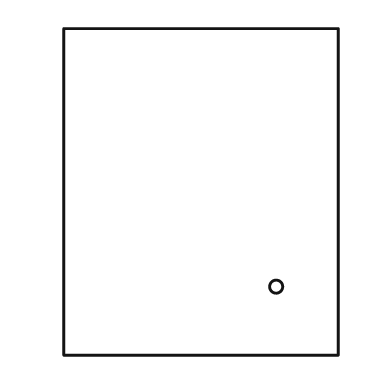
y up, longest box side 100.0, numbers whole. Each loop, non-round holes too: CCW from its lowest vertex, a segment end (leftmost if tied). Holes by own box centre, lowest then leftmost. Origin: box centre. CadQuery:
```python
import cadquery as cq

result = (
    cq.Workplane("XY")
    .moveTo(-42.0, -50.0)
    .lineTo(42.0, -50.0)
    .lineTo(42.0, 50.0)
    .lineTo(-42.0, 50.0)
    .close()
    .moveTo(23.0, -29.0)
    .circle(2.0)
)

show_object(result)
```